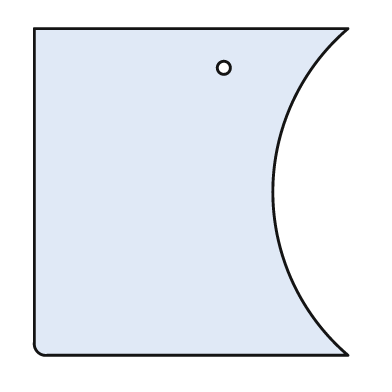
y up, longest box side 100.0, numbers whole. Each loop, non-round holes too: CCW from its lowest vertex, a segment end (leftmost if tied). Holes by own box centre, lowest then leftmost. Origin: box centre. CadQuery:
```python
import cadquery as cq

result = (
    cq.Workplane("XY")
    .moveTo(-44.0, -50.0)
    .lineTo(48.0, -50.0)
    .threePointArc((25.0, 0.0), (48.0, 50.0))
    .lineTo(-48.0, 50.0)
    .lineTo(-48.0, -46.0)
    .threePointArc((-47.0, -49.0), (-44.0, -50.0))
    .close()
    .moveTo(10.0, 38.0)
    .circle(2.0)
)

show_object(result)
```